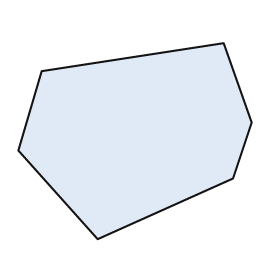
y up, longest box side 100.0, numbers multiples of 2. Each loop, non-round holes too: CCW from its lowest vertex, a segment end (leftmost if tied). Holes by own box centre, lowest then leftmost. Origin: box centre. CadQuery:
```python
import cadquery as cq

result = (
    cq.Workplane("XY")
    .moveTo(-16.0, -42.0)
    .lineTo(42.0, -16.0)
    .lineTo(50.0, 8.0)
    .lineTo(38.0, 42.0)
    .lineTo(-40.0, 30.0)
    .lineTo(-50.0, -4.0)
    .close()
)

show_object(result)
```